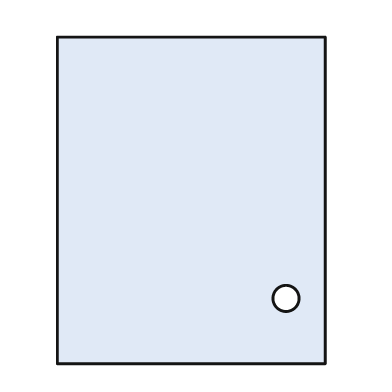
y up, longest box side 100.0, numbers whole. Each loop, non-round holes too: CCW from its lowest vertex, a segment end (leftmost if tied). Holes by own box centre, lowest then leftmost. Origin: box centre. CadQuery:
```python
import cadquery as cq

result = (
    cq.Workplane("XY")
    .moveTo(-41.0, -50.0)
    .lineTo(41.0, -50.0)
    .lineTo(41.0, 50.0)
    .lineTo(-41.0, 50.0)
    .close()
    .moveTo(29.0, -30.0)
    .circle(4.0)
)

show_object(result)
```